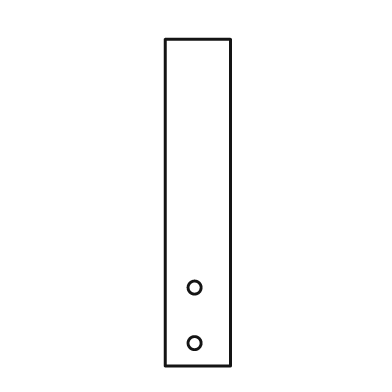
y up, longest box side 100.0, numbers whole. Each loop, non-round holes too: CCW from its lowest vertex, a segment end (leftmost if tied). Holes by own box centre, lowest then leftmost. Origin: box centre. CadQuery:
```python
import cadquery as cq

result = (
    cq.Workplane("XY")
    .moveTo(-10.0, -50.0)
    .lineTo(10.0, -50.0)
    .lineTo(10.0, 50.0)
    .lineTo(-10.0, 50.0)
    .close()
    .moveTo(-1.0, -43.0)
    .circle(2.0)
    .moveTo(-1.0, -26.0)
    .circle(2.0)
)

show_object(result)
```